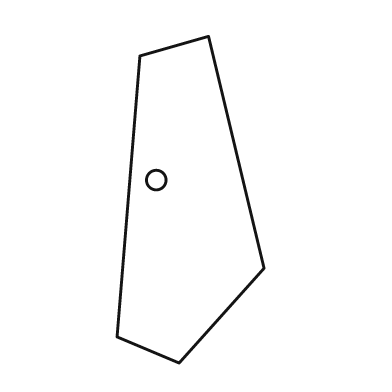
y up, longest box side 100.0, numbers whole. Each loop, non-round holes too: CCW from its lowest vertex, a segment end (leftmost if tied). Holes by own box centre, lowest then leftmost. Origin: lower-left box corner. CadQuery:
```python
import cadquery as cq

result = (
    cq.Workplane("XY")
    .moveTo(19.0, 0.0)
    .lineTo(45.0, 29.0)
    .lineTo(28.0, 100.0)
    .lineTo(7.0, 94.0)
    .lineTo(0.0, 8.0)
    .close()
    .moveTo(12.0, 56.0)
    .circle(3.0)
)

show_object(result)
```